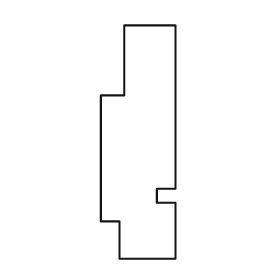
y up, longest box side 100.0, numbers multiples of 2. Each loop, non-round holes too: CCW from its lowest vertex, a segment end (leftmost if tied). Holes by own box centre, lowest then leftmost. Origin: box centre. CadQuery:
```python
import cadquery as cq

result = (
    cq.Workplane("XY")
    .moveTo(-8.0, -50.0)
    .lineTo(16.0, -50.0)
    .lineTo(16.0, -26.0)
    .lineTo(8.0, -26.0)
    .lineTo(8.0, -20.0)
    .lineTo(16.0, -20.0)
    .lineTo(16.0, 50.0)
    .lineTo(-6.0, 50.0)
    .lineTo(-6.0, 20.0)
    .lineTo(-16.0, 20.0)
    .lineTo(-16.0, -34.0)
    .lineTo(-8.0, -34.0)
    .close()
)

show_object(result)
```